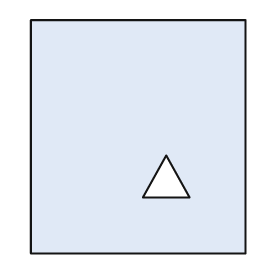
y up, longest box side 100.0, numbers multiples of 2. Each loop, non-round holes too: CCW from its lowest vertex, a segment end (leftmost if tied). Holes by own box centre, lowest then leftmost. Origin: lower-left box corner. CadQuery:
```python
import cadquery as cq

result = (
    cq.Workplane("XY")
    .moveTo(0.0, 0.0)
    .lineTo(92.0, 0.0)
    .lineTo(92.0, 100.0)
    .lineTo(0.0, 100.0)
    .close()
    .moveTo(48.0, 24.0)
    .lineTo(68.0, 24.0)
    .lineTo(58.0, 42.0)
    .close()
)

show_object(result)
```